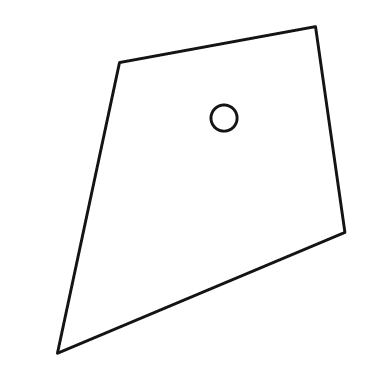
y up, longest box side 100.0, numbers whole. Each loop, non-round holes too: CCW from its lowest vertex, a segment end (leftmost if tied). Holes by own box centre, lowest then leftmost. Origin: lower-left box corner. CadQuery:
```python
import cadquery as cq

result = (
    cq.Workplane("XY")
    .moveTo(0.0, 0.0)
    .lineTo(88.0, 37.0)
    .lineTo(79.0, 100.0)
    .lineTo(19.0, 89.0)
    .close()
    .moveTo(51.0, 72.0)
    .circle(4.0)
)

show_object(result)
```